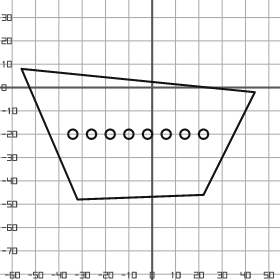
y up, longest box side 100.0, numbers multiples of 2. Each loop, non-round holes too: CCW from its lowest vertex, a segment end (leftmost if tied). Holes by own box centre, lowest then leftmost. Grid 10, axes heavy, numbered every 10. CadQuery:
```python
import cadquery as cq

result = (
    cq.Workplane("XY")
    .moveTo(-32.0, -48.0)
    .lineTo(22.0, -46.0)
    .lineTo(44.0, -2.0)
    .lineTo(-56.0, 8.0)
    .close()
    .moveTo(-34.0, -20.0)
    .circle(2.0)
    .moveTo(-26.0, -20.0)
    .circle(2.0)
    .moveTo(-18.0, -20.0)
    .circle(2.0)
    .moveTo(-10.0, -20.0)
    .circle(2.0)
    .moveTo(-2.0, -20.0)
    .circle(2.0)
    .moveTo(6.0, -20.0)
    .circle(2.0)
    .moveTo(14.0, -20.0)
    .circle(2.0)
    .moveTo(22.0, -20.0)
    .circle(2.0)
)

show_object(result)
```